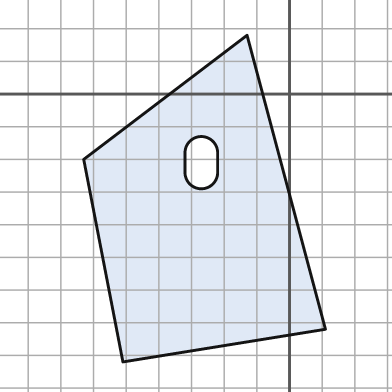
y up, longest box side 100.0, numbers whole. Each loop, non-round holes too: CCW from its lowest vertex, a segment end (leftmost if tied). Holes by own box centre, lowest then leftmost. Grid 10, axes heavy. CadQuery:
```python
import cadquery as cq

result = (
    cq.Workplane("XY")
    .moveTo(-51.0, -82.0)
    .lineTo(11.0, -72.0)
    .lineTo(-13.0, 18.0)
    .lineTo(-63.0, -20.0)
    .close()
    .moveTo(-32.0, -24.0)
    .threePointArc((-27.0, -29.0), (-22.0, -24.0))
    .lineTo(-22.0, -18.0)
    .threePointArc((-27.0, -13.0), (-32.0, -18.0))
    .close()
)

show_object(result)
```